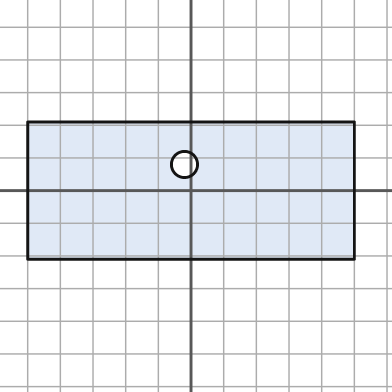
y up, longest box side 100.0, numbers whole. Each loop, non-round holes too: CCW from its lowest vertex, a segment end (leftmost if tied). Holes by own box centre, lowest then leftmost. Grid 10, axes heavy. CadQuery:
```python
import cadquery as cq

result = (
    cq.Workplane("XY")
    .moveTo(-50.0, -21.0)
    .lineTo(50.0, -21.0)
    .lineTo(50.0, 21.0)
    .lineTo(-50.0, 21.0)
    .close()
    .moveTo(-2.0, 8.0)
    .circle(4.0)
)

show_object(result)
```